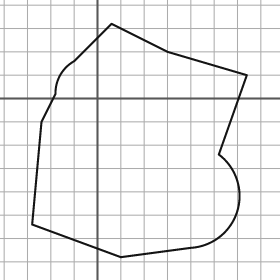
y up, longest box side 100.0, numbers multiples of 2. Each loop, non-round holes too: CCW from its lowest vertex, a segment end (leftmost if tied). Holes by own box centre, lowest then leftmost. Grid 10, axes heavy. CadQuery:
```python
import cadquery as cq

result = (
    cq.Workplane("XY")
    .moveTo(10.0, -68.0)
    .lineTo(40.0, -64.0)
    .threePointArc((60.0, -48.0), (52.0, -24.0))
    .lineTo(64.0, 10.0)
    .lineTo(30.0, 20.0)
    .lineTo(6.0, 32.0)
    .lineTo(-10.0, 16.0)
    .threePointArc((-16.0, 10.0), (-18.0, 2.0))
    .lineTo(-24.0, -10.0)
    .lineTo(-28.0, -54.0)
    .close()
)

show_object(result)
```